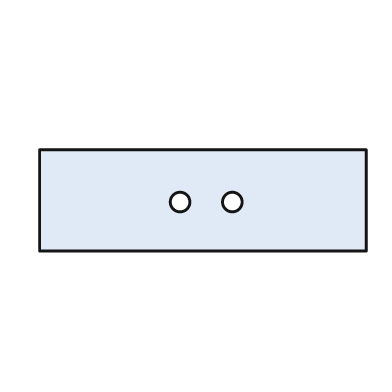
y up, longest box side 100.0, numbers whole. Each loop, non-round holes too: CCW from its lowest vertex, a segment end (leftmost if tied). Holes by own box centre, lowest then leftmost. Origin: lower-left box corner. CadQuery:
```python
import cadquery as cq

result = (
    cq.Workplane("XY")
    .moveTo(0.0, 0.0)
    .lineTo(100.0, 0.0)
    .lineTo(100.0, 31.0)
    .lineTo(0.0, 31.0)
    .close()
    .moveTo(43.0, 15.0)
    .circle(3.0)
    .moveTo(59.0, 15.0)
    .circle(3.0)
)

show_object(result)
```